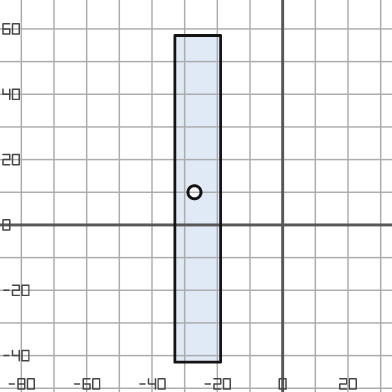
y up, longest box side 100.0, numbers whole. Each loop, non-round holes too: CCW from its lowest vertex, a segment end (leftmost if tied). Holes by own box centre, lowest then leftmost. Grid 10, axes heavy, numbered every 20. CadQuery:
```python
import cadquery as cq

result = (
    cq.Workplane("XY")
    .moveTo(-33.0, -42.0)
    .lineTo(-19.0, -42.0)
    .lineTo(-19.0, 58.0)
    .lineTo(-33.0, 58.0)
    .close()
    .moveTo(-27.0, 10.0)
    .circle(2.0)
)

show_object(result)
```